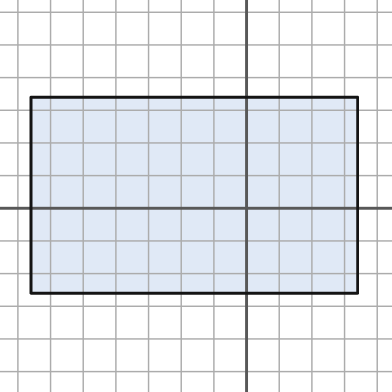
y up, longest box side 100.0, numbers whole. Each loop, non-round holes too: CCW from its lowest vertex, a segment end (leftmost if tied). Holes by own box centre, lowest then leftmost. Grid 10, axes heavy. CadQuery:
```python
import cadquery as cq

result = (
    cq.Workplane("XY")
    .moveTo(-66.0, -26.0)
    .lineTo(34.0, -26.0)
    .lineTo(34.0, 34.0)
    .lineTo(-66.0, 34.0)
    .close()
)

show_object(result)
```